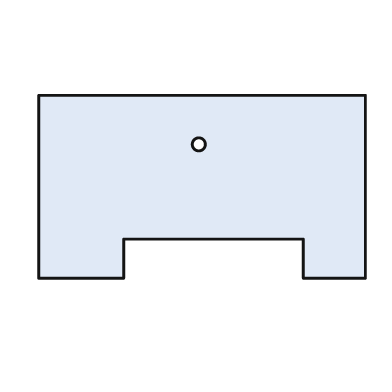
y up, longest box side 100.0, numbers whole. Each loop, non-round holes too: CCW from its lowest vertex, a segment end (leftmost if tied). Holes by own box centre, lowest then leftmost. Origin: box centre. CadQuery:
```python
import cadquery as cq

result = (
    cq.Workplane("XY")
    .moveTo(-50.0, -28.0)
    .lineTo(-24.0, -28.0)
    .lineTo(-24.0, -16.0)
    .lineTo(31.0, -16.0)
    .lineTo(31.0, -28.0)
    .lineTo(50.0, -28.0)
    .lineTo(50.0, 28.0)
    .lineTo(-50.0, 28.0)
    .close()
    .moveTo(-1.0, 13.0)
    .circle(2.0)
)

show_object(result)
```